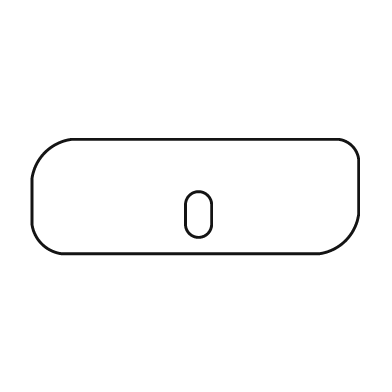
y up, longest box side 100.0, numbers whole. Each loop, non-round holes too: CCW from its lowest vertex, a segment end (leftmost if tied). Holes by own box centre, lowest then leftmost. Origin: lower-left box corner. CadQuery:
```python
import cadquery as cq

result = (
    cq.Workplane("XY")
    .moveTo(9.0, 0.0)
    .lineTo(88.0, 0.0)
    .threePointArc((96.0, 4.0), (100.0, 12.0))
    .lineTo(100.0, 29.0)
    .threePointArc((98.0, 33.0), (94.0, 35.0))
    .lineTo(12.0, 35.0)
    .threePointArc((4.0, 31.0), (0.0, 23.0))
    .lineTo(0.0, 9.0)
    .threePointArc((3.0, 3.0), (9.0, 0.0))
    .close()
    .moveTo(47.0, 9.0)
    .threePointArc((51.0, 5.0), (55.0, 9.0))
    .lineTo(55.0, 15.0)
    .threePointArc((51.0, 19.0), (47.0, 15.0))
    .close()
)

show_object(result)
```